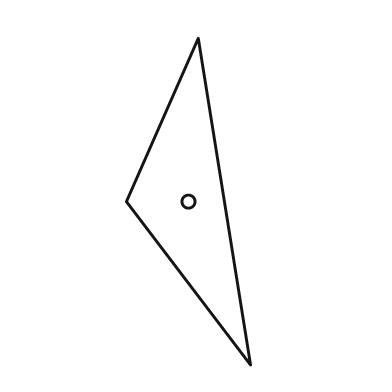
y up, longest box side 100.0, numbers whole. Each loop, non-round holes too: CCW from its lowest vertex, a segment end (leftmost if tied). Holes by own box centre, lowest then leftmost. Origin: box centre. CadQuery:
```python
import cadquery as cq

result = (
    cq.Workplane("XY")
    .moveTo(19.0, -50.0)
    .lineTo(3.0, 50.0)
    .lineTo(-19.0, 0.0)
    .close()
    .moveTo(0.0, 0.0)
    .circle(2.0)
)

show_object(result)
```